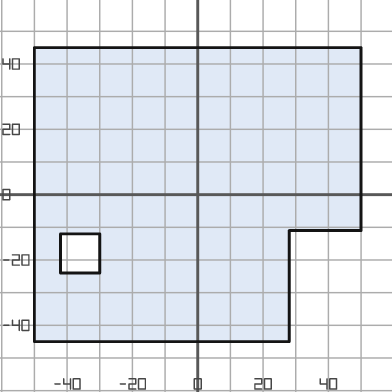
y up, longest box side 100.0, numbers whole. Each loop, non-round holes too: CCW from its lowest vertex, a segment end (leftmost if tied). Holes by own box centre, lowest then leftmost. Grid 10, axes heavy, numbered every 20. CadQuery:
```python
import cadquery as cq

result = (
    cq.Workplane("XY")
    .moveTo(-50.0, -45.0)
    .lineTo(28.0, -45.0)
    .lineTo(28.0, -11.0)
    .lineTo(50.0, -11.0)
    .lineTo(50.0, 45.0)
    .lineTo(-50.0, 45.0)
    .close()
    .moveTo(-42.0, -24.0)
    .lineTo(-30.0, -24.0)
    .lineTo(-30.0, -12.0)
    .lineTo(-42.0, -12.0)
    .close()
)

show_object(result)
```